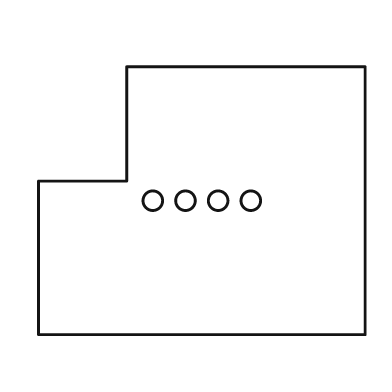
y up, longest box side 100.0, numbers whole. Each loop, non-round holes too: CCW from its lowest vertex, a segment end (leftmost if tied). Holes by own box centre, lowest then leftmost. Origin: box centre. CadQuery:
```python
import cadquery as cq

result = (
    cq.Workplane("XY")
    .moveTo(-50.0, -41.0)
    .lineTo(50.0, -41.0)
    .lineTo(50.0, 41.0)
    .lineTo(-23.0, 41.0)
    .lineTo(-23.0, 6.0)
    .lineTo(-50.0, 6.0)
    .close()
    .moveTo(-15.0, 0.0)
    .circle(3.0)
    .moveTo(-5.0, 0.0)
    .circle(3.0)
    .moveTo(5.0, 0.0)
    .circle(3.0)
    .moveTo(15.0, 0.0)
    .circle(3.0)
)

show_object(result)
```